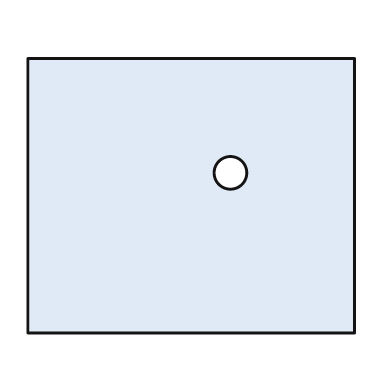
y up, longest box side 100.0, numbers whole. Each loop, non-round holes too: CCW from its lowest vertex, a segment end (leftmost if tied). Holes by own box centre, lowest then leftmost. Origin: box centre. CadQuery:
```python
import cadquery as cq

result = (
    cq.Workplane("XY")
    .moveTo(-50.0, -42.0)
    .lineTo(50.0, -42.0)
    .lineTo(50.0, 42.0)
    .lineTo(-50.0, 42.0)
    .close()
    .moveTo(12.0, 7.0)
    .circle(5.0)
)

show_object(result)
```